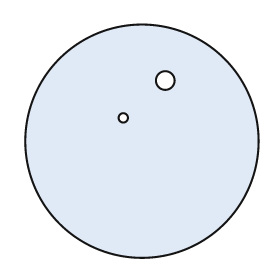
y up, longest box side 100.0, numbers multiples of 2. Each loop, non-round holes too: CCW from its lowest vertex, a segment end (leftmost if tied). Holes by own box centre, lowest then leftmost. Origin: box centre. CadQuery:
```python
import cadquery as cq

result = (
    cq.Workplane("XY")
    .moveTo(0.0, 0.0)
    .circle(50.0)
    .moveTo(-8.0, 10.0)
    .circle(2.0)
    .moveTo(10.0, 26.0)
    .circle(4.0)
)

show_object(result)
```